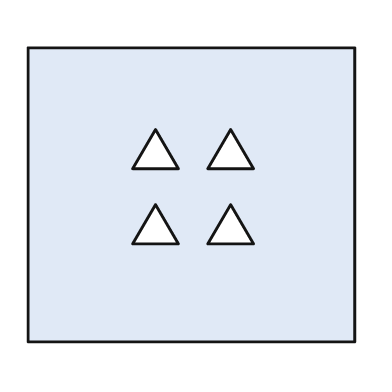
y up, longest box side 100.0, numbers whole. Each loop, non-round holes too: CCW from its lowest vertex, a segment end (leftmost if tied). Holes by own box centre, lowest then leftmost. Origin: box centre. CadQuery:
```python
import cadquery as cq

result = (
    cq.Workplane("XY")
    .moveTo(-50.0, -45.0)
    .lineTo(50.0, -45.0)
    .lineTo(50.0, 45.0)
    .lineTo(-50.0, 45.0)
    .close()
    .moveTo(-18.0, -15.0)
    .lineTo(-4.0, -15.0)
    .lineTo(-11.0, -3.0)
    .close()
    .moveTo(5.0, -15.0)
    .lineTo(19.0, -15.0)
    .lineTo(12.0, -3.0)
    .close()
    .moveTo(-18.0, 8.0)
    .lineTo(-4.0, 8.0)
    .lineTo(-11.0, 20.0)
    .close()
    .moveTo(5.0, 8.0)
    .lineTo(19.0, 8.0)
    .lineTo(12.0, 20.0)
    .close()
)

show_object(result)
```